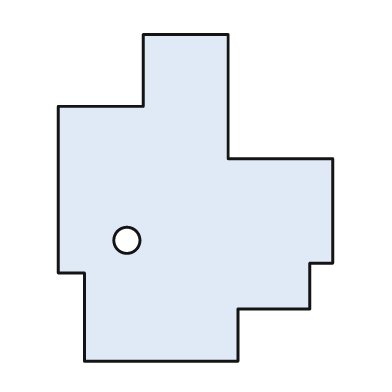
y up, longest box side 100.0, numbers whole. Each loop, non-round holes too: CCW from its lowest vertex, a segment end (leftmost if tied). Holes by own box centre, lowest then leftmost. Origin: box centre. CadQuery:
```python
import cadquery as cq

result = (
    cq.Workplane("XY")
    .moveTo(-34.0, -50.0)
    .lineTo(13.0, -50.0)
    .lineTo(13.0, -34.0)
    .lineTo(35.0, -34.0)
    .lineTo(35.0, -20.0)
    .lineTo(42.0, -20.0)
    .lineTo(42.0, 12.0)
    .lineTo(10.0, 12.0)
    .lineTo(10.0, 50.0)
    .lineTo(-16.0, 50.0)
    .lineTo(-16.0, 28.0)
    .lineTo(-42.0, 28.0)
    .lineTo(-42.0, -23.0)
    .lineTo(-34.0, -23.0)
    .close()
    .moveTo(-21.0, -13.0)
    .circle(4.0)
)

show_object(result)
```